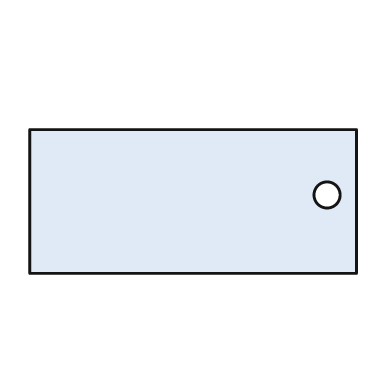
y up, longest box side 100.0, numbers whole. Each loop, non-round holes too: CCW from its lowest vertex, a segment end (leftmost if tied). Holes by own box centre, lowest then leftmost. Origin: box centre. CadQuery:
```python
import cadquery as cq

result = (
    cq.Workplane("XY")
    .moveTo(-50.0, -22.0)
    .lineTo(50.0, -22.0)
    .lineTo(50.0, 22.0)
    .lineTo(-50.0, 22.0)
    .close()
    .moveTo(41.0, 2.0)
    .circle(4.0)
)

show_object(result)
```